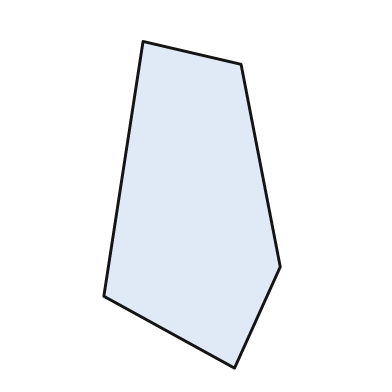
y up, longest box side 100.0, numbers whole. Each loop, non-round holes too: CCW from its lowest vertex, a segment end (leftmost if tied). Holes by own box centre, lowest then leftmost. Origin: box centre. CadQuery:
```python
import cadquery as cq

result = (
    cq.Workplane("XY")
    .moveTo(13.0, -50.0)
    .lineTo(27.0, -19.0)
    .lineTo(15.0, 43.0)
    .lineTo(-15.0, 50.0)
    .lineTo(-27.0, -28.0)
    .close()
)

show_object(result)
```